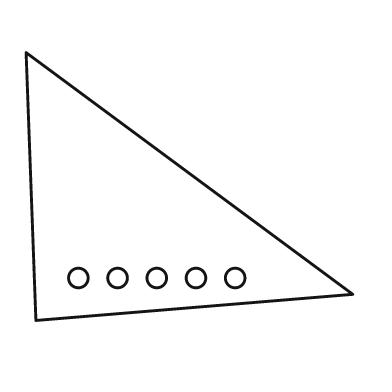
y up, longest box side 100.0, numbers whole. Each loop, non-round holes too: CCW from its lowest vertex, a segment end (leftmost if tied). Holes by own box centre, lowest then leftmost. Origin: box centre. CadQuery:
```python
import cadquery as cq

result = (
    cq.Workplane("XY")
    .moveTo(-47.0, -41.0)
    .lineTo(50.0, -33.0)
    .lineTo(-50.0, 41.0)
    .close()
    .moveTo(-34.0, -28.0)
    .circle(3.0)
    .moveTo(-22.0, -28.0)
    .circle(3.0)
    .moveTo(-10.0, -28.0)
    .circle(3.0)
    .moveTo(2.0, -28.0)
    .circle(3.0)
    .moveTo(14.0, -28.0)
    .circle(3.0)
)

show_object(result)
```